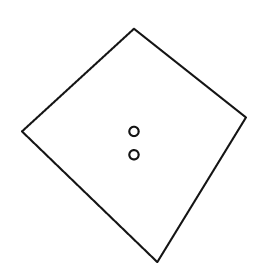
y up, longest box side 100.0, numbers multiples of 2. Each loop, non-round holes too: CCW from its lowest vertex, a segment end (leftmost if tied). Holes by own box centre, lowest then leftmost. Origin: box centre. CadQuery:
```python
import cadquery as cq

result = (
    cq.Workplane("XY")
    .moveTo(10.0, -50.0)
    .lineTo(48.0, 12.0)
    .lineTo(0.0, 50.0)
    .lineTo(-48.0, 6.0)
    .close()
    .moveTo(0.0, -4.0)
    .circle(2.0)
    .moveTo(0.0, 6.0)
    .circle(2.0)
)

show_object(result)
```